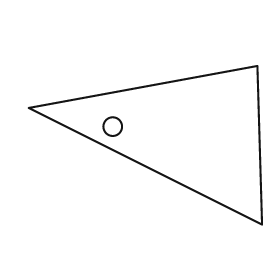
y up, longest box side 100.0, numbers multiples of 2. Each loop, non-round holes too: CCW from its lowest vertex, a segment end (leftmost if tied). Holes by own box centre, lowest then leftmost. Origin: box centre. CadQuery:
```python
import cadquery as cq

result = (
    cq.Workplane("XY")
    .moveTo(50.0, -34.0)
    .lineTo(48.0, 34.0)
    .lineTo(-50.0, 16.0)
    .close()
    .moveTo(-14.0, 8.0)
    .circle(4.0)
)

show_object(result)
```